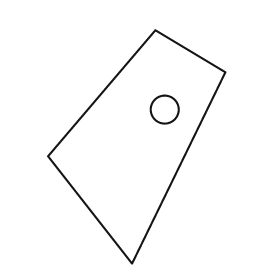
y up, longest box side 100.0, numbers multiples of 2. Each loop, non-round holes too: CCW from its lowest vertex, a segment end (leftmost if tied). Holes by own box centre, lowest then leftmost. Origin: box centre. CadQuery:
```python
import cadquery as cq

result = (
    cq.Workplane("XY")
    .moveTo(-2.0, -50.0)
    .lineTo(38.0, 32.0)
    .lineTo(8.0, 50.0)
    .lineTo(-38.0, -4.0)
    .close()
    .moveTo(12.0, 16.0)
    .circle(6.0)
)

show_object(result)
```